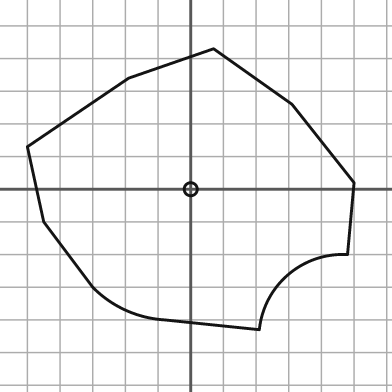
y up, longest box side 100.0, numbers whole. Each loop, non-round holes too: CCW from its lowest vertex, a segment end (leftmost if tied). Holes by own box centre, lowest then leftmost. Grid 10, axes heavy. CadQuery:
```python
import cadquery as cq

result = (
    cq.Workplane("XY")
    .moveTo(21.0, -43.0)
    .threePointArc((30.0, -26.0), (48.0, -20.0))
    .lineTo(50.0, 2.0)
    .lineTo(31.0, 26.0)
    .lineTo(7.0, 43.0)
    .lineTo(-19.0, 34.0)
    .lineTo(-50.0, 13.0)
    .lineTo(-45.0, -10.0)
    .lineTo(-30.0, -30.0)
    .threePointArc((-20.0, -37.0), (-8.0, -40.0))
    .close()
    .moveTo(0.0, 0.0)
    .circle(2.0)
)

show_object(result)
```